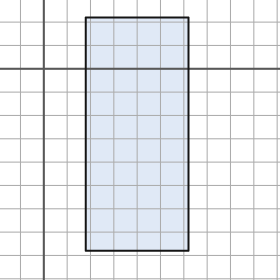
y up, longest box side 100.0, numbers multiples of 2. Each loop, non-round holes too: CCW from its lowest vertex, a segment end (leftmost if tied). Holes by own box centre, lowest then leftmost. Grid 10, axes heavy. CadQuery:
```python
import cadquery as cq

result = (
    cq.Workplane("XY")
    .moveTo(18.0, -78.0)
    .lineTo(62.0, -78.0)
    .lineTo(62.0, 22.0)
    .lineTo(18.0, 22.0)
    .close()
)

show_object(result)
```